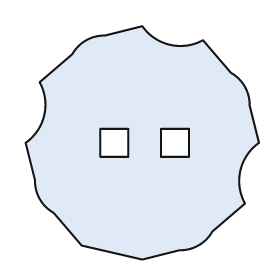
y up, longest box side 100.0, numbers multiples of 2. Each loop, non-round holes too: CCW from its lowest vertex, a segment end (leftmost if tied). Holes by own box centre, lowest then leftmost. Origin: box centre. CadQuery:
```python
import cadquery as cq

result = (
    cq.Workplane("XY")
    .moveTo(0.0, -50.0)
    .lineTo(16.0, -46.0)
    .threePointArc((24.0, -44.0), (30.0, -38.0))
    .lineTo(44.0, -26.0)
    .threePointArc((42.0, -12.0), (50.0, 0.0))
    .lineTo(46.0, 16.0)
    .threePointArc((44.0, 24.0), (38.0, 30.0))
    .lineTo(26.0, 44.0)
    .threePointArc((12.0, 42.0), (0.0, 50.0))
    .lineTo(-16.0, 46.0)
    .threePointArc((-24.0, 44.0), (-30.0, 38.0))
    .lineTo(-44.0, 26.0)
    .threePointArc((-42.0, 12.0), (-50.0, 0.0))
    .lineTo(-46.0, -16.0)
    .threePointArc((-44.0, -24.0), (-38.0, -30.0))
    .lineTo(-26.0, -44.0)
    .close()
    .moveTo(-18.0, -6.0)
    .lineTo(-6.0, -6.0)
    .lineTo(-6.0, 6.0)
    .lineTo(-18.0, 6.0)
    .close()
    .moveTo(8.0, -6.0)
    .lineTo(20.0, -6.0)
    .lineTo(20.0, 6.0)
    .lineTo(8.0, 6.0)
    .close()
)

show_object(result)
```